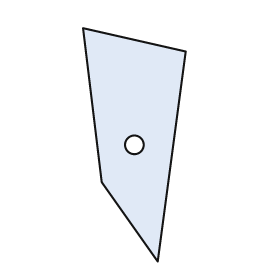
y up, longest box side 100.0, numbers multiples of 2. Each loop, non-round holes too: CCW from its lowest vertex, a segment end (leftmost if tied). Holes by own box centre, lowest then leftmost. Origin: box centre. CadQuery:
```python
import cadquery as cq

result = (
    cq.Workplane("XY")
    .moveTo(10.0, -50.0)
    .lineTo(22.0, 40.0)
    .lineTo(-22.0, 50.0)
    .lineTo(-14.0, -16.0)
    .close()
    .moveTo(0.0, 0.0)
    .circle(4.0)
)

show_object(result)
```